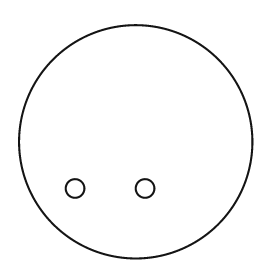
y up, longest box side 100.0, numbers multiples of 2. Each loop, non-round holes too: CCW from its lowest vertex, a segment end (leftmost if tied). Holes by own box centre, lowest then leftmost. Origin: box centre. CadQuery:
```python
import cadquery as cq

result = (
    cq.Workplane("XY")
    .moveTo(0.0, 0.0)
    .circle(50.0)
    .moveTo(-26.0, -20.0)
    .circle(4.0)
    .moveTo(4.0, -20.0)
    .circle(4.0)
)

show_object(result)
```